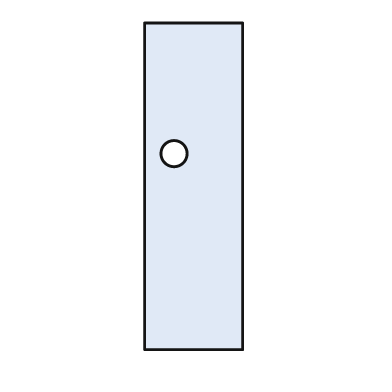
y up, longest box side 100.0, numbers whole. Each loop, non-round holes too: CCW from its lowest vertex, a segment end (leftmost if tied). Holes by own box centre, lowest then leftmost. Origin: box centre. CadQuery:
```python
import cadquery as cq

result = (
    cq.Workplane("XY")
    .moveTo(-15.0, -50.0)
    .lineTo(15.0, -50.0)
    .lineTo(15.0, 50.0)
    .lineTo(-15.0, 50.0)
    .close()
    .moveTo(-6.0, 10.0)
    .circle(4.0)
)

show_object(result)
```